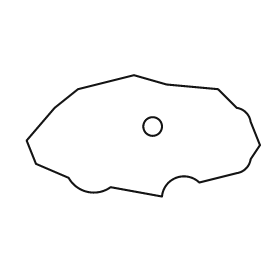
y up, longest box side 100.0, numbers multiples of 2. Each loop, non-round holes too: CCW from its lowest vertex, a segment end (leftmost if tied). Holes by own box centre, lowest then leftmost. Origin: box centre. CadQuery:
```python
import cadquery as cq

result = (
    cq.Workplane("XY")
    .moveTo(8.0, -26.0)
    .threePointArc((14.0, -18.0), (24.0, -20.0))
    .lineTo(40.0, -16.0)
    .threePointArc((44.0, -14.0), (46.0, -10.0))
    .lineTo(50.0, -4.0)
    .lineTo(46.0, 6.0)
    .threePointArc((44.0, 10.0), (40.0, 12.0))
    .lineTo(32.0, 20.0)
    .lineTo(10.0, 22.0)
    .lineTo(-4.0, 26.0)
    .lineTo(-28.0, 20.0)
    .lineTo(-38.0, 12.0)
    .lineTo(-50.0, -2.0)
    .lineTo(-46.0, -12.0)
    .lineTo(-32.0, -18.0)
    .threePointArc((-24.0, -24.0), (-14.0, -22.0))
    .close()
    .moveTo(4.0, 4.0)
    .circle(4.0)
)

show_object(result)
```